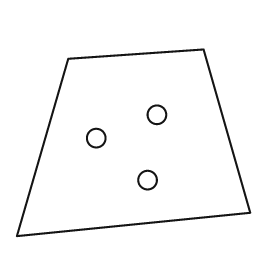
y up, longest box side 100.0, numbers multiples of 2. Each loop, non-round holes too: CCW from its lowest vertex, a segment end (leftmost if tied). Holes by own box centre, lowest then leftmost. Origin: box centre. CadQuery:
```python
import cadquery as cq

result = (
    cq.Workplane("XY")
    .moveTo(-50.0, -40.0)
    .lineTo(50.0, -30.0)
    .lineTo(30.0, 40.0)
    .lineTo(-28.0, 36.0)
    .close()
    .moveTo(6.0, -16.0)
    .circle(4.0)
    .moveTo(-16.0, 2.0)
    .circle(4.0)
    .moveTo(10.0, 12.0)
    .circle(4.0)
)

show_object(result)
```